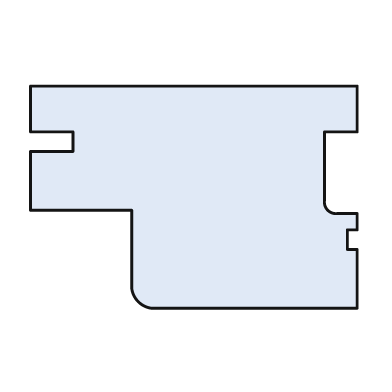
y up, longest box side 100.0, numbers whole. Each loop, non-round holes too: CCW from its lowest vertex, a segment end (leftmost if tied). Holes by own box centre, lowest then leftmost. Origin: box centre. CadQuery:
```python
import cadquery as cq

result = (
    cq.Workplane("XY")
    .moveTo(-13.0, -34.0)
    .lineTo(50.0, -34.0)
    .lineTo(50.0, -16.0)
    .lineTo(47.0, -16.0)
    .lineTo(47.0, -10.0)
    .lineTo(50.0, -10.0)
    .lineTo(50.0, -5.0)
    .lineTo(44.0, -5.0)
    .threePointArc((41.0, -4.0), (40.0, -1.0))
    .lineTo(40.0, 20.0)
    .lineTo(50.0, 20.0)
    .lineTo(50.0, 34.0)
    .lineTo(-50.0, 34.0)
    .lineTo(-50.0, 20.0)
    .lineTo(-37.0, 20.0)
    .lineTo(-37.0, 14.0)
    .lineTo(-50.0, 14.0)
    .lineTo(-50.0, -4.0)
    .lineTo(-19.0, -4.0)
    .lineTo(-19.0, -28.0)
    .threePointArc((-17.0, -32.0), (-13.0, -34.0))
    .close()
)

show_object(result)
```